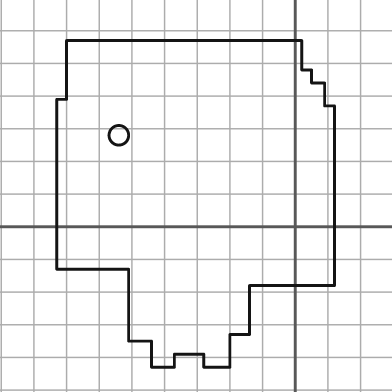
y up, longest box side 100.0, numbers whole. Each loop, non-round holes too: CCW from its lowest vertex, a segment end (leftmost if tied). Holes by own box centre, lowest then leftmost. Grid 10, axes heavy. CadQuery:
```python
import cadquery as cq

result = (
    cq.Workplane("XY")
    .moveTo(-44.0, -43.0)
    .lineTo(-37.0, -43.0)
    .lineTo(-37.0, -39.0)
    .lineTo(-28.0, -39.0)
    .lineTo(-28.0, -43.0)
    .lineTo(-20.0, -43.0)
    .lineTo(-20.0, -33.0)
    .lineTo(-14.0, -33.0)
    .lineTo(-14.0, -18.0)
    .lineTo(12.0, -18.0)
    .lineTo(12.0, 37.0)
    .lineTo(9.0, 37.0)
    .lineTo(9.0, 44.0)
    .lineTo(5.0, 44.0)
    .lineTo(5.0, 48.0)
    .lineTo(2.0, 48.0)
    .lineTo(2.0, 57.0)
    .lineTo(-70.0, 57.0)
    .lineTo(-70.0, 39.0)
    .lineTo(-73.0, 39.0)
    .lineTo(-73.0, -13.0)
    .lineTo(-51.0, -13.0)
    .lineTo(-51.0, -35.0)
    .lineTo(-44.0, -35.0)
    .close()
    .moveTo(-54.0, 28.0)
    .circle(3.0)
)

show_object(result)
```